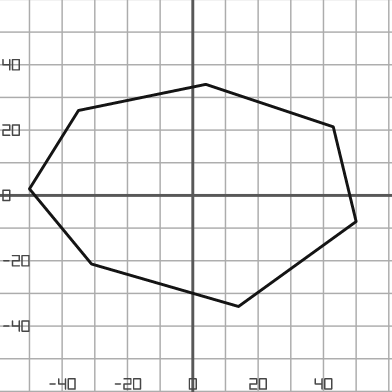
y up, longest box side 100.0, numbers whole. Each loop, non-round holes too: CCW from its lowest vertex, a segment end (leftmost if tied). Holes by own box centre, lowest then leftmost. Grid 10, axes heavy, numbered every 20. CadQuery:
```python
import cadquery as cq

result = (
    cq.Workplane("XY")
    .moveTo(14.0, -34.0)
    .lineTo(50.0, -8.0)
    .lineTo(43.0, 21.0)
    .lineTo(4.0, 34.0)
    .lineTo(-35.0, 26.0)
    .lineTo(-50.0, 2.0)
    .lineTo(-31.0, -21.0)
    .close()
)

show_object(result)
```